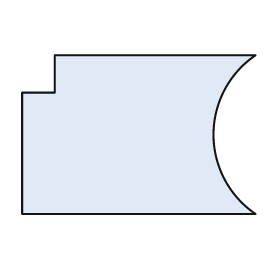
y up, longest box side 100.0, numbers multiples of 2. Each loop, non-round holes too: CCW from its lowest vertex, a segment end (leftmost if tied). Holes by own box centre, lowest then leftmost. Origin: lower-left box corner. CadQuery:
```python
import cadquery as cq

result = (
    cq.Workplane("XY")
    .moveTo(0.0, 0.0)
    .lineTo(100.0, 0.0)
    .threePointArc((82.0, 34.0), (100.0, 68.0))
    .lineTo(14.0, 68.0)
    .lineTo(14.0, 52.0)
    .lineTo(0.0, 52.0)
    .close()
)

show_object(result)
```